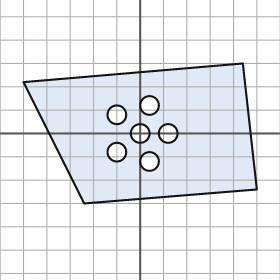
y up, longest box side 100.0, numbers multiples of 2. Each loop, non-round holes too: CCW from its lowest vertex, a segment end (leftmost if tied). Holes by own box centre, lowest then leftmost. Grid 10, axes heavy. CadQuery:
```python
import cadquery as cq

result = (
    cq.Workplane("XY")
    .moveTo(-24.0, -30.0)
    .lineTo(50.0, -24.0)
    .lineTo(44.0, 30.0)
    .lineTo(-50.0, 22.0)
    .close()
    .moveTo(4.0, -12.0)
    .circle(4.0)
    .moveTo(-10.0, -8.0)
    .circle(4.0)
    .moveTo(0.0, 0.0)
    .circle(4.0)
    .moveTo(12.0, 0.0)
    .circle(4.0)
    .moveTo(-10.0, 8.0)
    .circle(4.0)
    .moveTo(4.0, 12.0)
    .circle(4.0)
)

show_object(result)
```